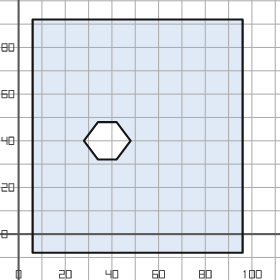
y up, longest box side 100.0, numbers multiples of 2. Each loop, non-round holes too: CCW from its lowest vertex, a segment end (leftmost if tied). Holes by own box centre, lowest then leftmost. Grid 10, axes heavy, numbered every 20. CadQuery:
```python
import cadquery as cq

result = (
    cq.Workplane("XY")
    .moveTo(6.0, -8.0)
    .lineTo(96.0, -8.0)
    .lineTo(96.0, 92.0)
    .lineTo(6.0, 92.0)
    .close()
    .moveTo(34.0, 32.0)
    .lineTo(42.0, 32.0)
    .lineTo(48.0, 40.0)
    .lineTo(42.0, 48.0)
    .lineTo(34.0, 48.0)
    .lineTo(28.0, 40.0)
    .close()
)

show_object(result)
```